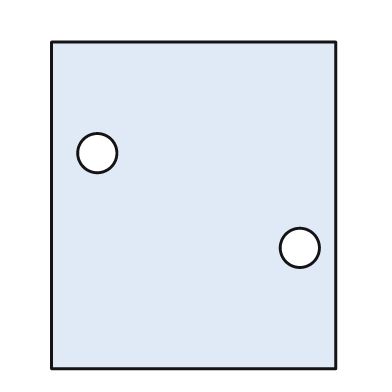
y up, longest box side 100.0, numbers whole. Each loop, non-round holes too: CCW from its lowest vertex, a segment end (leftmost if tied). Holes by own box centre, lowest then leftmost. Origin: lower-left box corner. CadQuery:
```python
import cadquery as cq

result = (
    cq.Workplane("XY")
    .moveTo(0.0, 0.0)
    .lineTo(87.0, 0.0)
    .lineTo(87.0, 100.0)
    .lineTo(0.0, 100.0)
    .close()
    .moveTo(76.0, 37.0)
    .circle(6.0)
    .moveTo(14.0, 66.0)
    .circle(6.0)
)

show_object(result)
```